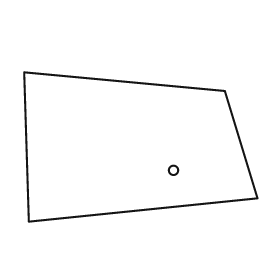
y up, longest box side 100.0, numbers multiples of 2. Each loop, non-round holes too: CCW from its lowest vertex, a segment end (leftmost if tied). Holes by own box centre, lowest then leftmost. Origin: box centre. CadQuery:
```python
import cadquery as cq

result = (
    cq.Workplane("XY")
    .moveTo(-48.0, -32.0)
    .lineTo(50.0, -22.0)
    .lineTo(36.0, 24.0)
    .lineTo(-50.0, 32.0)
    .close()
    .moveTo(14.0, -10.0)
    .circle(2.0)
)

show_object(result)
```